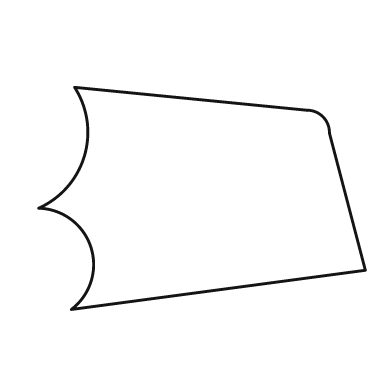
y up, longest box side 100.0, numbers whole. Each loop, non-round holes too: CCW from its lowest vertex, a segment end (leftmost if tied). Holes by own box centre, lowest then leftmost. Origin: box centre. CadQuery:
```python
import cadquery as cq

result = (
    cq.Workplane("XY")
    .moveTo(-40.0, -34.0)
    .lineTo(50.0, -22.0)
    .lineTo(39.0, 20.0)
    .threePointArc((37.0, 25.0), (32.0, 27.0))
    .lineTo(-39.0, 34.0)
    .threePointArc((-36.0, 13.0), (-50.0, -3.0))
    .threePointArc((-34.0, -15.0), (-40.0, -34.0))
    .close()
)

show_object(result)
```